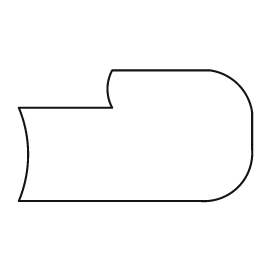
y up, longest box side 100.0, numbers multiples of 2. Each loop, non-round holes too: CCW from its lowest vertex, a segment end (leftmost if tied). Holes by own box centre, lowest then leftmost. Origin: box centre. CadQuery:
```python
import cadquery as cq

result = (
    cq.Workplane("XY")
    .moveTo(-50.0, -28.0)
    .lineTo(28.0, -28.0)
    .threePointArc((44.0, -22.0), (50.0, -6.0))
    .lineTo(50.0, 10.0)
    .threePointArc((44.0, 22.0), (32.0, 28.0))
    .lineTo(-10.0, 28.0)
    .threePointArc((-12.0, 20.0), (-10.0, 12.0))
    .lineTo(-50.0, 12.0)
    .threePointArc((-46.0, -8.0), (-50.0, -28.0))
    .close()
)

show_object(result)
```